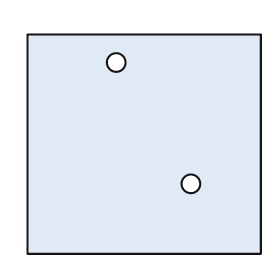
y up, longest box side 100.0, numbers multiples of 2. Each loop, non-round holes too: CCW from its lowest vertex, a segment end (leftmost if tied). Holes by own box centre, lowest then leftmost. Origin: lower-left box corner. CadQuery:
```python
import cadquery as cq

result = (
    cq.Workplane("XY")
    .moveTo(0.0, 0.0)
    .lineTo(100.0, 0.0)
    .lineTo(100.0, 94.0)
    .lineTo(0.0, 94.0)
    .close()
    .moveTo(70.0, 30.0)
    .circle(4.0)
    .moveTo(38.0, 82.0)
    .circle(4.0)
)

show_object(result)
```